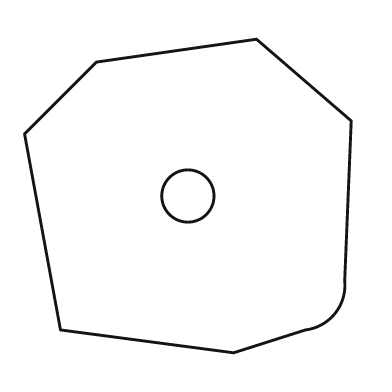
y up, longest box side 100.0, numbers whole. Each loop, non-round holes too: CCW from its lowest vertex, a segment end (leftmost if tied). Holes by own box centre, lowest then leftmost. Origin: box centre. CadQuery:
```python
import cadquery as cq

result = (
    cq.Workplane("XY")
    .moveTo(14.0, -48.0)
    .lineTo(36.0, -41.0)
    .threePointArc((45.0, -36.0), (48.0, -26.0))
    .lineTo(50.0, 23.0)
    .lineTo(21.0, 48.0)
    .lineTo(-28.0, 41.0)
    .lineTo(-50.0, 19.0)
    .lineTo(-39.0, -41.0)
    .close()
    .moveTo(0.0, 0.0)
    .circle(8.0)
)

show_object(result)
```